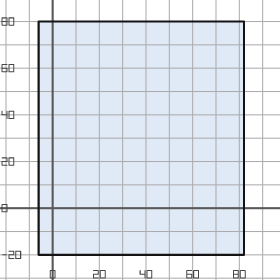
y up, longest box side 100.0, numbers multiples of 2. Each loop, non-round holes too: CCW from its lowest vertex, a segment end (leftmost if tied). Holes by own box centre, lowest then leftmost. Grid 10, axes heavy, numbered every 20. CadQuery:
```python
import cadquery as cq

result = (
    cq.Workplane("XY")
    .moveTo(-6.0, -20.0)
    .lineTo(82.0, -20.0)
    .lineTo(82.0, 80.0)
    .lineTo(-6.0, 80.0)
    .close()
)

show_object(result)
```